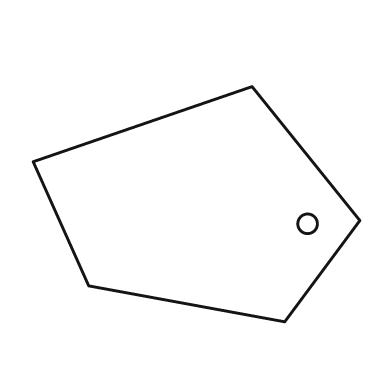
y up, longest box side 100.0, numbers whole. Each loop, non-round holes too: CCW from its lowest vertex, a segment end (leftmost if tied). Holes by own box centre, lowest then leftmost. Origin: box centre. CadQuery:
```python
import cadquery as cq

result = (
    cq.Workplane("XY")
    .moveTo(27.0, -36.0)
    .lineTo(50.0, -5.0)
    .lineTo(17.0, 36.0)
    .lineTo(-50.0, 13.0)
    .lineTo(-33.0, -25.0)
    .close()
    .moveTo(34.0, -6.0)
    .circle(3.0)
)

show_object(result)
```